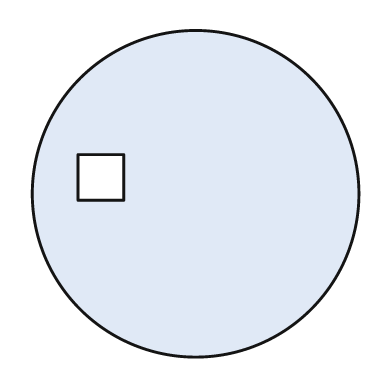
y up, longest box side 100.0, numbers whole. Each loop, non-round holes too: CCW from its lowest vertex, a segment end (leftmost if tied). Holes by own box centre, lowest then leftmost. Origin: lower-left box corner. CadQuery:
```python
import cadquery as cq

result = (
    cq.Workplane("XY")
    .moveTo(50.0, 50.0)
    .circle(50.0)
    .moveTo(14.0, 48.0)
    .lineTo(28.0, 48.0)
    .lineTo(28.0, 62.0)
    .lineTo(14.0, 62.0)
    .close()
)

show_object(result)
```